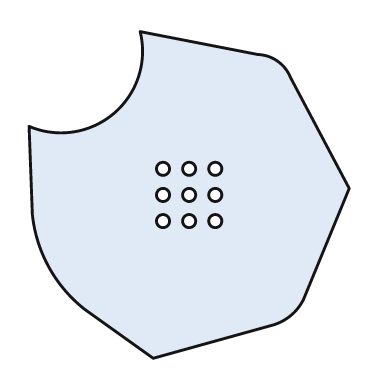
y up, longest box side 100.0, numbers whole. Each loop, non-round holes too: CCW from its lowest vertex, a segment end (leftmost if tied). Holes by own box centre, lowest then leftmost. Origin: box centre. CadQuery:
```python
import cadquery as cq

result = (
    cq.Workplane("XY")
    .moveTo(-11.0, -50.0)
    .lineTo(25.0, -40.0)
    .threePointArc((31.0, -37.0), (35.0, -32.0))
    .lineTo(49.0, 2.0)
    .lineTo(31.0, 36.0)
    .threePointArc((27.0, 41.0), (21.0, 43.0))
    .lineTo(-15.0, 50.0)
    .threePointArc((-23.0, 25.0), (-49.0, 21.0))
    .lineTo(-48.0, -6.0)
    .threePointArc((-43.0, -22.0), (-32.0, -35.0))
    .close()
    .moveTo(-8.0, -8.0)
    .circle(2.0)
    .moveTo(0.0, -8.0)
    .circle(2.0)
    .moveTo(8.0, -8.0)
    .circle(2.0)
    .moveTo(-8.0, 0.0)
    .circle(2.0)
    .moveTo(0.0, 0.0)
    .circle(2.0)
    .moveTo(8.0, 0.0)
    .circle(2.0)
    .moveTo(-8.0, 8.0)
    .circle(2.0)
    .moveTo(0.0, 8.0)
    .circle(2.0)
    .moveTo(8.0, 8.0)
    .circle(2.0)
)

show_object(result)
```